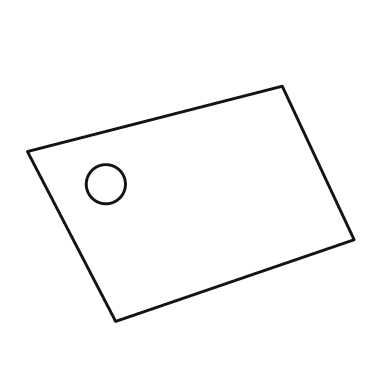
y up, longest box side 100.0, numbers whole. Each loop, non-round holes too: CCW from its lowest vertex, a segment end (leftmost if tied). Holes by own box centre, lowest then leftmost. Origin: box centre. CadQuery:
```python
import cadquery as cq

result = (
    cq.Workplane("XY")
    .moveTo(-23.0, -36.0)
    .lineTo(50.0, -11.0)
    .lineTo(28.0, 36.0)
    .lineTo(-50.0, 16.0)
    .close()
    .moveTo(-26.0, 6.0)
    .circle(6.0)
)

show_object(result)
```